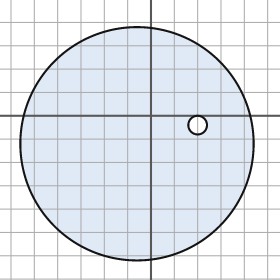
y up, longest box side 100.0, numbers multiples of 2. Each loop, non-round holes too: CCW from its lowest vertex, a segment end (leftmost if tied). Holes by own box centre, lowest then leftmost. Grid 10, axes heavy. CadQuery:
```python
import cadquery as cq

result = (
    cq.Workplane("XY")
    .moveTo(-6.0, -12.0)
    .circle(50.0)
    .moveTo(20.0, -4.0)
    .circle(4.0)
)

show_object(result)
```